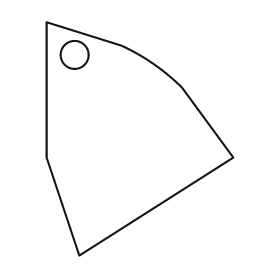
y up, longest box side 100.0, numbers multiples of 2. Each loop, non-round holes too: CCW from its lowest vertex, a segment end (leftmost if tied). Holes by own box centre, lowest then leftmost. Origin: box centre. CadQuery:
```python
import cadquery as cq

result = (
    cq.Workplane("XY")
    .moveTo(-26.0, -50.0)
    .lineTo(40.0, -8.0)
    .lineTo(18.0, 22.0)
    .threePointArc((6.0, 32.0), (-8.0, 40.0))
    .lineTo(-40.0, 50.0)
    .lineTo(-40.0, -8.0)
    .close()
    .moveTo(-28.0, 36.0)
    .circle(6.0)
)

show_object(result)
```